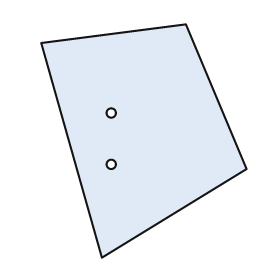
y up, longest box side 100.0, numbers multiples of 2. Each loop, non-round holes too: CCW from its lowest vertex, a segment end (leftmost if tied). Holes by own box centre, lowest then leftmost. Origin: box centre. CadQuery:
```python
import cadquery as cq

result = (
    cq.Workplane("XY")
    .moveTo(-18.0, -50.0)
    .lineTo(44.0, -12.0)
    .lineTo(18.0, 50.0)
    .lineTo(-44.0, 42.0)
    .close()
    .moveTo(-14.0, -10.0)
    .circle(2.0)
    .moveTo(-14.0, 12.0)
    .circle(2.0)
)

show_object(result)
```